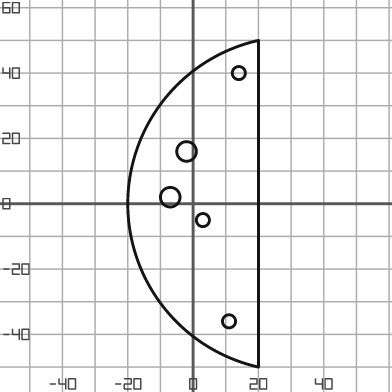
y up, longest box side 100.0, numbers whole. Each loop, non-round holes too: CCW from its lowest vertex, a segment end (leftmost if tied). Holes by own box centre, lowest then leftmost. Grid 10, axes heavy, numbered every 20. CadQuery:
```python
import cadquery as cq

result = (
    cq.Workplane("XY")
    .moveTo(20.0, -50.0)
    .lineTo(20.0, 50.0)
    .threePointArc((-20.0, 0.0), (20.0, -50.0))
    .close()
    .moveTo(11.0, -36.0)
    .circle(2.0)
    .moveTo(3.0, -5.0)
    .circle(2.0)
    .moveTo(-7.0, 2.0)
    .circle(3.0)
    .moveTo(-2.0, 16.0)
    .circle(3.0)
    .moveTo(14.0, 40.0)
    .circle(2.0)
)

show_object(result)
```